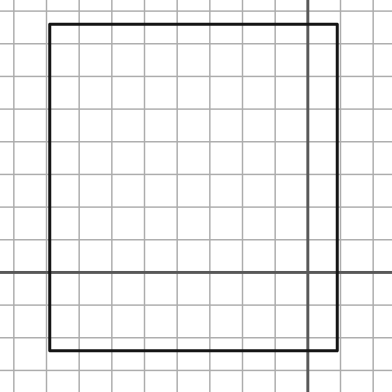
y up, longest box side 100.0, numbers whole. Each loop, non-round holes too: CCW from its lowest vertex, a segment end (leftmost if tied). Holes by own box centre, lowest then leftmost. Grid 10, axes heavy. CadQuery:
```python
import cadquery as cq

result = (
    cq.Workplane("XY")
    .moveTo(-79.0, -24.0)
    .lineTo(9.0, -24.0)
    .lineTo(9.0, 76.0)
    .lineTo(-79.0, 76.0)
    .close()
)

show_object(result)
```